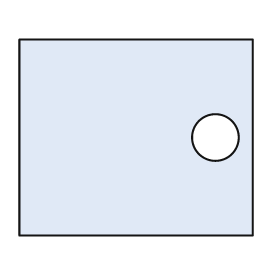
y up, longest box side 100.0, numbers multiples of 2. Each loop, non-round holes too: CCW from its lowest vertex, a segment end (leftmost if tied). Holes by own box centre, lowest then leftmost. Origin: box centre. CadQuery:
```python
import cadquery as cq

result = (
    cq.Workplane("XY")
    .moveTo(-50.0, -42.0)
    .lineTo(50.0, -42.0)
    .lineTo(50.0, 42.0)
    .lineTo(-50.0, 42.0)
    .close()
    .moveTo(34.0, 0.0)
    .circle(10.0)
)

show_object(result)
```